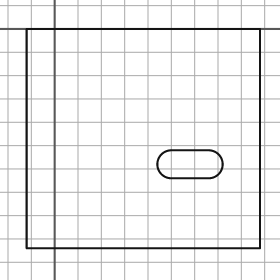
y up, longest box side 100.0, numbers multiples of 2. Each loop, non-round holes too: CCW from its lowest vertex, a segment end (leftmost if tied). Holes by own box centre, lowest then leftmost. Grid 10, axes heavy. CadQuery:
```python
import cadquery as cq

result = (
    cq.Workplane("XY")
    .moveTo(-12.0, -94.0)
    .lineTo(88.0, -94.0)
    .lineTo(88.0, 0.0)
    .lineTo(-12.0, 0.0)
    .close()
    .moveTo(50.0, -64.0)
    .lineTo(66.0, -64.0)
    .threePointArc((72.0, -58.0), (66.0, -52.0))
    .lineTo(50.0, -52.0)
    .threePointArc((44.0, -58.0), (50.0, -64.0))
    .close()
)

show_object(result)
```